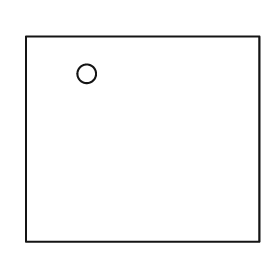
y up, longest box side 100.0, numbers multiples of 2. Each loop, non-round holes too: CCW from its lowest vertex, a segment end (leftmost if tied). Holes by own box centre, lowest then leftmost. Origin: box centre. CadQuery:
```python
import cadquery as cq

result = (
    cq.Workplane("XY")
    .moveTo(-50.0, -44.0)
    .lineTo(50.0, -44.0)
    .lineTo(50.0, 44.0)
    .lineTo(-50.0, 44.0)
    .close()
    .moveTo(-24.0, 28.0)
    .circle(4.0)
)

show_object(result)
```